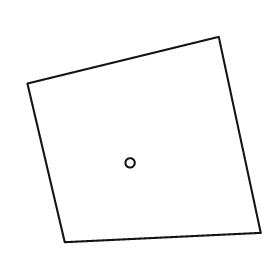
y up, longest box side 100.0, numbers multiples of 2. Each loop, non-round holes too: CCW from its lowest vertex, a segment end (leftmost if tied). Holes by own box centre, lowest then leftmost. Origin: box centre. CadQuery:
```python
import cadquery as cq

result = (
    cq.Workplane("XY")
    .moveTo(-34.0, -44.0)
    .lineTo(50.0, -40.0)
    .lineTo(32.0, 44.0)
    .lineTo(-50.0, 24.0)
    .close()
    .moveTo(-6.0, -10.0)
    .circle(2.0)
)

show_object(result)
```